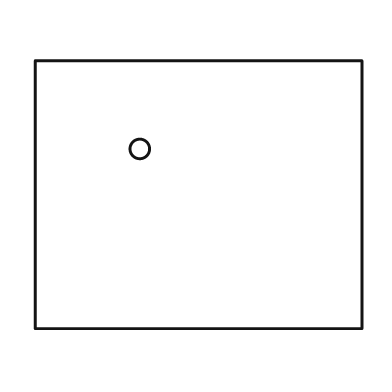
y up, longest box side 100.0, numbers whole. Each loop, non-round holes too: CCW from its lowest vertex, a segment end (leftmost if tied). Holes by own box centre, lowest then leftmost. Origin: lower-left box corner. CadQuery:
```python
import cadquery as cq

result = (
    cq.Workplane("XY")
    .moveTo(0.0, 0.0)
    .lineTo(100.0, 0.0)
    .lineTo(100.0, 82.0)
    .lineTo(0.0, 82.0)
    .close()
    .moveTo(32.0, 55.0)
    .circle(3.0)
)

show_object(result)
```